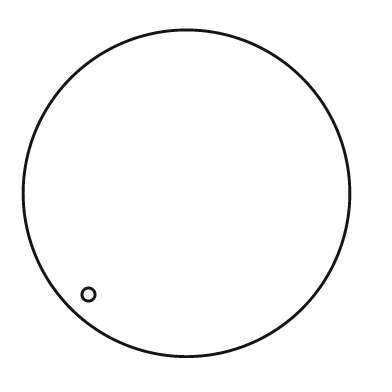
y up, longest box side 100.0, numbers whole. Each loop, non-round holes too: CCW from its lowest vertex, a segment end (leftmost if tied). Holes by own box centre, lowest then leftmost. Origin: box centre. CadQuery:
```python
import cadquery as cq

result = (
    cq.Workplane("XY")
    .moveTo(0.0, 0.0)
    .circle(50.0)
    .moveTo(-30.0, -31.0)
    .circle(2.0)
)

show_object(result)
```